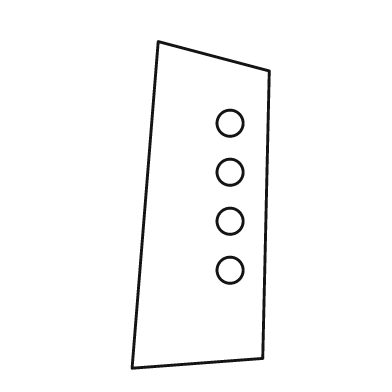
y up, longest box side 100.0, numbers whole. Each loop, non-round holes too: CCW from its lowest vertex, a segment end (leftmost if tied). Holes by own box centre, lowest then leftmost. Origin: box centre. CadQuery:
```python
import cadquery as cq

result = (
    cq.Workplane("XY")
    .moveTo(-21.0, -50.0)
    .lineTo(19.0, -47.0)
    .lineTo(21.0, 41.0)
    .lineTo(-13.0, 50.0)
    .close()
    .moveTo(9.0, -20.0)
    .circle(4.0)
    .moveTo(9.0, -5.0)
    .circle(4.0)
    .moveTo(9.0, 10.0)
    .circle(4.0)
    .moveTo(9.0, 25.0)
    .circle(4.0)
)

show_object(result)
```